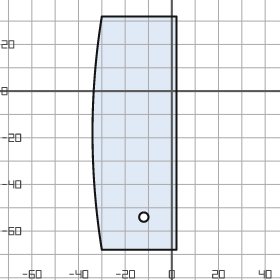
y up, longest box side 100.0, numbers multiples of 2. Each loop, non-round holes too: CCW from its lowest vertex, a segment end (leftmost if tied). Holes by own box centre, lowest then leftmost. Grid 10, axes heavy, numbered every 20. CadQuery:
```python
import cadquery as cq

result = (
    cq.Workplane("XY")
    .moveTo(-30.0, -68.0)
    .lineTo(2.0, -68.0)
    .lineTo(2.0, 32.0)
    .lineTo(-30.0, 32.0)
    .threePointArc((-34.0, -18.0), (-30.0, -68.0))
    .close()
    .moveTo(-12.0, -54.0)
    .circle(2.0)
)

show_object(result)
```